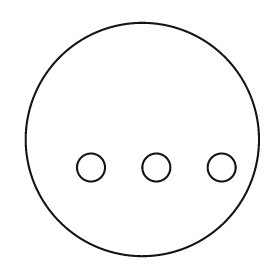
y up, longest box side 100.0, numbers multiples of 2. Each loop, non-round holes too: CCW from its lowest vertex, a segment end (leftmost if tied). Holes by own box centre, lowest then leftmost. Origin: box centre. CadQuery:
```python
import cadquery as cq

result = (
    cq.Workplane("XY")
    .moveTo(0.0, 0.0)
    .circle(50.0)
    .moveTo(-22.0, -12.0)
    .circle(6.0)
    .moveTo(6.0, -12.0)
    .circle(6.0)
    .moveTo(34.0, -12.0)
    .circle(6.0)
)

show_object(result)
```